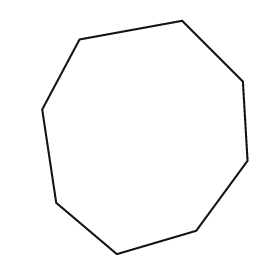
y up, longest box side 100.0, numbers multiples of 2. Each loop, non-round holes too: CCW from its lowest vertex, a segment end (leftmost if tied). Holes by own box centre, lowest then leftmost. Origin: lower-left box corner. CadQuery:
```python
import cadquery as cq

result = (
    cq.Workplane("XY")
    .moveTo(32.0, 0.0)
    .lineTo(66.0, 10.0)
    .lineTo(88.0, 40.0)
    .lineTo(86.0, 74.0)
    .lineTo(60.0, 100.0)
    .lineTo(16.0, 92.0)
    .lineTo(0.0, 62.0)
    .lineTo(6.0, 22.0)
    .close()
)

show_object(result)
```